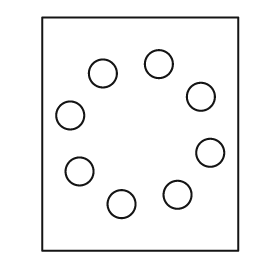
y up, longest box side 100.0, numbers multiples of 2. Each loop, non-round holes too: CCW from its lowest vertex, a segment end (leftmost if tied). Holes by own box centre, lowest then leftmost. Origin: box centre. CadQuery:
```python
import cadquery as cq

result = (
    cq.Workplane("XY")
    .moveTo(-42.0, -50.0)
    .lineTo(42.0, -50.0)
    .lineTo(42.0, 50.0)
    .lineTo(-42.0, 50.0)
    .close()
    .moveTo(-8.0, -30.0)
    .circle(6.0)
    .moveTo(16.0, -26.0)
    .circle(6.0)
    .moveTo(-26.0, -16.0)
    .circle(6.0)
    .moveTo(30.0, -8.0)
    .circle(6.0)
    .moveTo(-30.0, 8.0)
    .circle(6.0)
    .moveTo(26.0, 16.0)
    .circle(6.0)
    .moveTo(-16.0, 26.0)
    .circle(6.0)
    .moveTo(8.0, 30.0)
    .circle(6.0)
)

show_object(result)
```